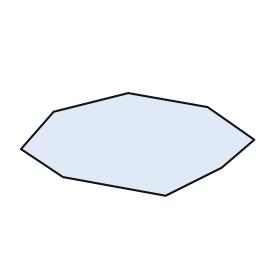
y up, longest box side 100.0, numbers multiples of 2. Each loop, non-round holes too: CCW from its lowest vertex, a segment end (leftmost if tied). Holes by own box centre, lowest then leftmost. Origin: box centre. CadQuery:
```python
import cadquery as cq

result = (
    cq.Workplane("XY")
    .moveTo(12.0, -22.0)
    .lineTo(36.0, -10.0)
    .lineTo(50.0, 2.0)
    .lineTo(30.0, 16.0)
    .lineTo(-4.0, 22.0)
    .lineTo(-36.0, 14.0)
    .lineTo(-50.0, -2.0)
    .lineTo(-32.0, -14.0)
    .close()
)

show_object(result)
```